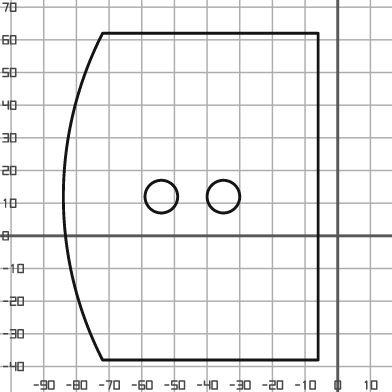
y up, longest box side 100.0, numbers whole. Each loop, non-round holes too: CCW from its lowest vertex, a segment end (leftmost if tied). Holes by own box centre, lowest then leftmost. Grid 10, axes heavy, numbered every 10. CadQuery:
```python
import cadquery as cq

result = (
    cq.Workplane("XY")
    .moveTo(-72.0, -38.0)
    .lineTo(-6.0, -38.0)
    .lineTo(-6.0, 62.0)
    .lineTo(-72.0, 62.0)
    .threePointArc((-84.0, 12.0), (-72.0, -38.0))
    .close()
    .moveTo(-54.0, 12.0)
    .circle(5.0)
    .moveTo(-35.0, 12.0)
    .circle(5.0)
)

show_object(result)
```